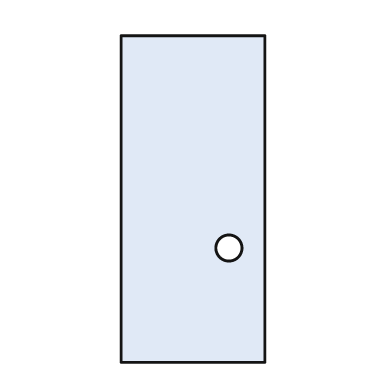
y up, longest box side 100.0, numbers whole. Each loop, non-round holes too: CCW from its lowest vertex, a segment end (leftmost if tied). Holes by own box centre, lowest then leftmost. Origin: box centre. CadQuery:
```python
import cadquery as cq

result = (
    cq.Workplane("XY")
    .moveTo(-22.0, -50.0)
    .lineTo(22.0, -50.0)
    .lineTo(22.0, 50.0)
    .lineTo(-22.0, 50.0)
    .close()
    .moveTo(11.0, -15.0)
    .circle(4.0)
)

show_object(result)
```